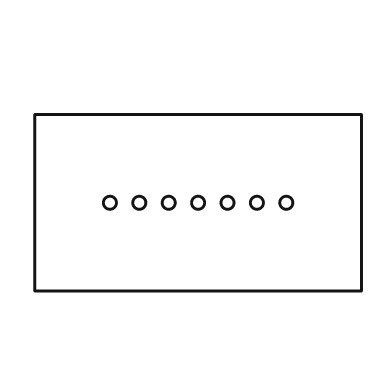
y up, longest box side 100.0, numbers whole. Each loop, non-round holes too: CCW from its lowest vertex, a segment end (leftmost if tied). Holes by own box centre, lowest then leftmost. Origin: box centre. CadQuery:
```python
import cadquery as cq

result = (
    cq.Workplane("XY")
    .moveTo(-50.0, -27.0)
    .lineTo(50.0, -27.0)
    .lineTo(50.0, 27.0)
    .lineTo(-50.0, 27.0)
    .close()
    .moveTo(-27.0, 0.0)
    .circle(2.0)
    .moveTo(-18.0, 0.0)
    .circle(2.0)
    .moveTo(-9.0, 0.0)
    .circle(2.0)
    .moveTo(0.0, 0.0)
    .circle(2.0)
    .moveTo(9.0, 0.0)
    .circle(2.0)
    .moveTo(18.0, 0.0)
    .circle(2.0)
    .moveTo(27.0, 0.0)
    .circle(2.0)
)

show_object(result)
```